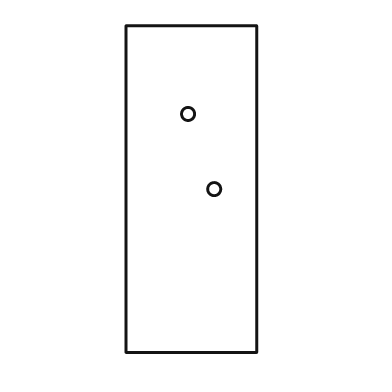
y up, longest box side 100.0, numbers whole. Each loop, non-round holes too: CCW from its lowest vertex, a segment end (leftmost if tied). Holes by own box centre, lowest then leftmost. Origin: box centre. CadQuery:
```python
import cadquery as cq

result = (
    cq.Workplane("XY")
    .moveTo(-20.0, -50.0)
    .lineTo(20.0, -50.0)
    .lineTo(20.0, 50.0)
    .lineTo(-20.0, 50.0)
    .close()
    .moveTo(7.0, 0.0)
    .circle(2.0)
    .moveTo(-1.0, 23.0)
    .circle(2.0)
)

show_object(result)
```